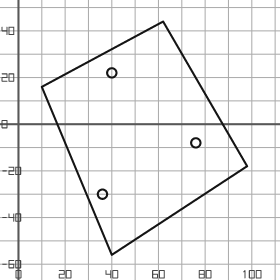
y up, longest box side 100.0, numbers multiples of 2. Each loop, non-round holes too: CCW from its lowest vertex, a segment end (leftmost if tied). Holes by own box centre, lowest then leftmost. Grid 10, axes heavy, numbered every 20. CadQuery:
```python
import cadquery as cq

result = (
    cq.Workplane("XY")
    .moveTo(40.0, -56.0)
    .lineTo(98.0, -18.0)
    .lineTo(62.0, 44.0)
    .lineTo(10.0, 16.0)
    .close()
    .moveTo(36.0, -30.0)
    .circle(2.0)
    .moveTo(76.0, -8.0)
    .circle(2.0)
    .moveTo(40.0, 22.0)
    .circle(2.0)
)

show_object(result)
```